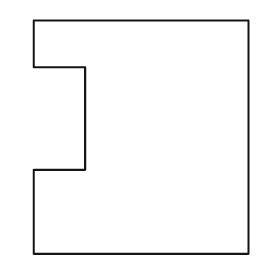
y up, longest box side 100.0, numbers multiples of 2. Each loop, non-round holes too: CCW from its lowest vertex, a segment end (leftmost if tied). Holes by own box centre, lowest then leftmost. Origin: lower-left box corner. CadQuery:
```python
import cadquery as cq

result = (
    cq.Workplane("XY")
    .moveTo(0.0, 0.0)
    .lineTo(92.0, 0.0)
    .lineTo(92.0, 100.0)
    .lineTo(0.0, 100.0)
    .lineTo(0.0, 80.0)
    .lineTo(22.0, 80.0)
    .lineTo(22.0, 36.0)
    .lineTo(0.0, 36.0)
    .close()
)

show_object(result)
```